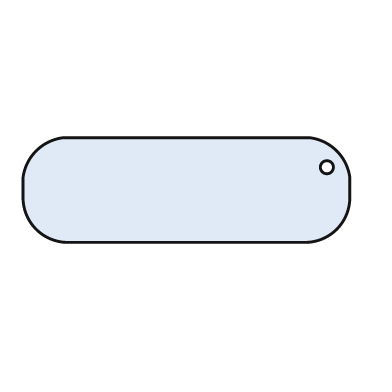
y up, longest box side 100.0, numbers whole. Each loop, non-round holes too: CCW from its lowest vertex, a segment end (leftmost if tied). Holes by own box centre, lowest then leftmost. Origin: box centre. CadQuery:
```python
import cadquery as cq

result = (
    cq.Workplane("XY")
    .moveTo(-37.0, -16.0)
    .lineTo(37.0, -16.0)
    .threePointArc((46.0, -12.0), (50.0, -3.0))
    .lineTo(50.0, 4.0)
    .threePointArc((46.0, 12.0), (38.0, 16.0))
    .lineTo(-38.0, 16.0)
    .threePointArc((-46.0, 12.0), (-50.0, 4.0))
    .lineTo(-50.0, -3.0)
    .threePointArc((-46.0, -12.0), (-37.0, -16.0))
    .close()
    .moveTo(43.0, 7.0)
    .circle(2.0)
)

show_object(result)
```